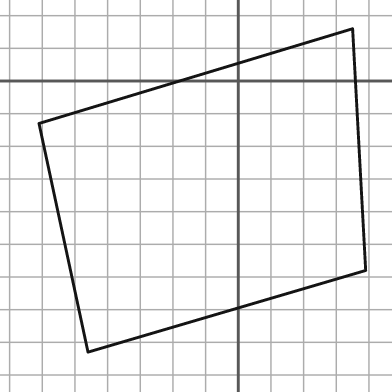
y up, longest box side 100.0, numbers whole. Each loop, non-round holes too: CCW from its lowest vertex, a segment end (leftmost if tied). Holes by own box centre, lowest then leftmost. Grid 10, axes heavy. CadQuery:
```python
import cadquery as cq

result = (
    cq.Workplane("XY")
    .moveTo(-46.0, -83.0)
    .lineTo(39.0, -58.0)
    .lineTo(35.0, 16.0)
    .lineTo(-61.0, -13.0)
    .close()
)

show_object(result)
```